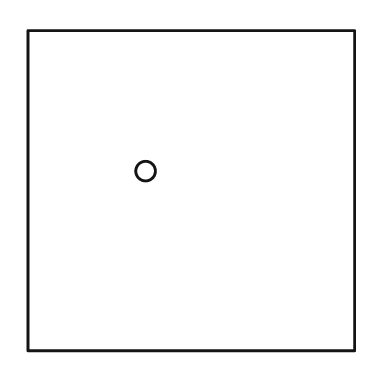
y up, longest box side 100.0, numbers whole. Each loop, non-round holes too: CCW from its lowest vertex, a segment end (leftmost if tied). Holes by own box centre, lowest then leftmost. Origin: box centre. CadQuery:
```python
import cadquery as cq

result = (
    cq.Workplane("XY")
    .moveTo(-50.0, -49.0)
    .lineTo(50.0, -49.0)
    .lineTo(50.0, 49.0)
    .lineTo(-50.0, 49.0)
    .close()
    .moveTo(-14.0, 6.0)
    .circle(3.0)
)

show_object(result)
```